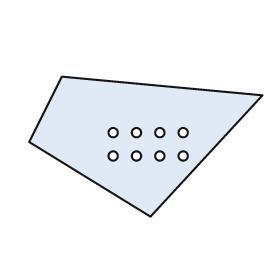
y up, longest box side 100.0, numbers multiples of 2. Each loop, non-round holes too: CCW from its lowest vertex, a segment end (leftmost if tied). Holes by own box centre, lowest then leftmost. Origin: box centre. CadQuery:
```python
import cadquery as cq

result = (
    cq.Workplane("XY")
    .moveTo(2.0, -30.0)
    .lineTo(50.0, 22.0)
    .lineTo(-36.0, 30.0)
    .lineTo(-50.0, 2.0)
    .close()
    .moveTo(-14.0, -4.0)
    .circle(2.0)
    .moveTo(-4.0, -4.0)
    .circle(2.0)
    .moveTo(6.0, -4.0)
    .circle(2.0)
    .moveTo(16.0, -4.0)
    .circle(2.0)
    .moveTo(-14.0, 6.0)
    .circle(2.0)
    .moveTo(-4.0, 6.0)
    .circle(2.0)
    .moveTo(6.0, 6.0)
    .circle(2.0)
    .moveTo(16.0, 6.0)
    .circle(2.0)
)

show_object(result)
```